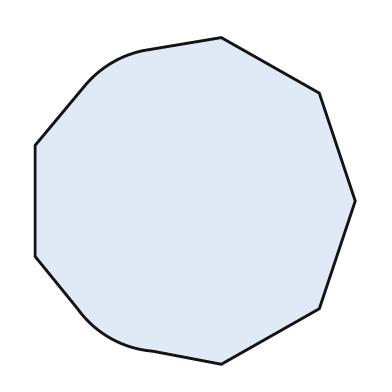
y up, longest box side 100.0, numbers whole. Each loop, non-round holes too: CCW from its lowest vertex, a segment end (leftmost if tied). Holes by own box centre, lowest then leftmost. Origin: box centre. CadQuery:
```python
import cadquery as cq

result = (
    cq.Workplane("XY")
    .moveTo(8.0, -50.0)
    .lineTo(38.0, -33.0)
    .lineTo(49.0, 0.0)
    .lineTo(38.0, 33.0)
    .lineTo(8.0, 50.0)
    .lineTo(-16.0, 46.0)
    .threePointArc((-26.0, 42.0), (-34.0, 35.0))
    .lineTo(-49.0, 17.0)
    .lineTo(-49.0, -17.0)
    .lineTo(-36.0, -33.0)
    .threePointArc((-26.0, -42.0), (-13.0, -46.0))
    .close()
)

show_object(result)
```